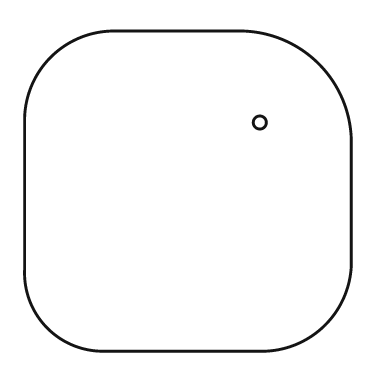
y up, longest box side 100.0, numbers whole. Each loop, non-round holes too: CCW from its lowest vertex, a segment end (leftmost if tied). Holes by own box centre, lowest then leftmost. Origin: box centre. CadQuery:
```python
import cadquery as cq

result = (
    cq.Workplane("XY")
    .moveTo(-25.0, -49.0)
    .lineTo(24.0, -49.0)
    .threePointArc((42.0, -41.0), (50.0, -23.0))
    .lineTo(50.0, 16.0)
    .threePointArc((40.0, 39.0), (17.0, 49.0))
    .lineTo(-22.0, 49.0)
    .threePointArc((-42.0, 41.0), (-50.0, 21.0))
    .lineTo(-50.0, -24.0)
    .threePointArc((-43.0, -42.0), (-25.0, -49.0))
    .close()
    .moveTo(22.0, 21.0)
    .circle(2.0)
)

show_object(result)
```